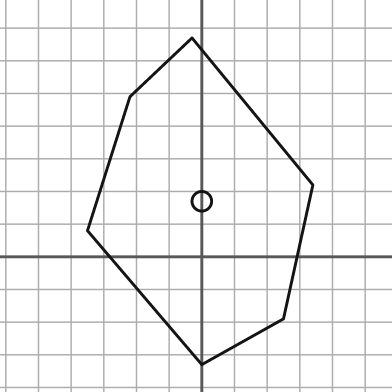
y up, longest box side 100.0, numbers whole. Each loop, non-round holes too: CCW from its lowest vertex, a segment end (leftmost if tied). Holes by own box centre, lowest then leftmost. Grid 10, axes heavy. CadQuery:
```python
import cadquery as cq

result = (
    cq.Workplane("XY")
    .moveTo(0.0, -33.0)
    .lineTo(25.0, -19.0)
    .lineTo(34.0, 22.0)
    .lineTo(-3.0, 67.0)
    .lineTo(-22.0, 49.0)
    .lineTo(-35.0, 8.0)
    .close()
    .moveTo(0.0, 17.0)
    .circle(3.0)
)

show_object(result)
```